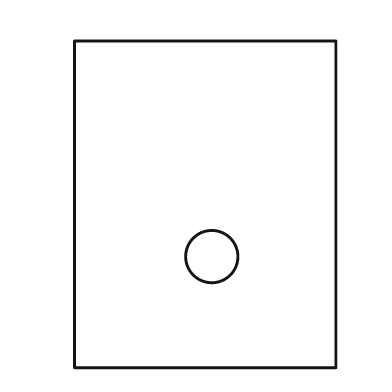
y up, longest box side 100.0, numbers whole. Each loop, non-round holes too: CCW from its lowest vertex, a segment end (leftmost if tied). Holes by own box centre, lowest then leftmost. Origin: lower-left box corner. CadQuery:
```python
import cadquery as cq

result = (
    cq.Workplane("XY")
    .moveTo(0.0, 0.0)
    .lineTo(80.0, 0.0)
    .lineTo(80.0, 100.0)
    .lineTo(0.0, 100.0)
    .close()
    .moveTo(42.0, 34.0)
    .circle(8.0)
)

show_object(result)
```